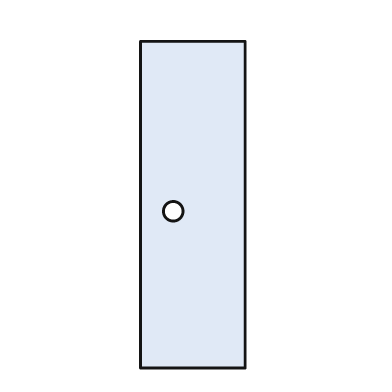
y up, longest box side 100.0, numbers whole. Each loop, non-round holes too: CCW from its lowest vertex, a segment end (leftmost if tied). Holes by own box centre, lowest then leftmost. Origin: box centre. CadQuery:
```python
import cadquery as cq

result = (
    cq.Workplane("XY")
    .moveTo(-16.0, -50.0)
    .lineTo(16.0, -50.0)
    .lineTo(16.0, 50.0)
    .lineTo(-16.0, 50.0)
    .close()
    .moveTo(-6.0, -2.0)
    .circle(3.0)
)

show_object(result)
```